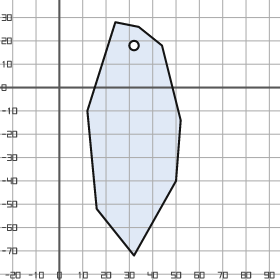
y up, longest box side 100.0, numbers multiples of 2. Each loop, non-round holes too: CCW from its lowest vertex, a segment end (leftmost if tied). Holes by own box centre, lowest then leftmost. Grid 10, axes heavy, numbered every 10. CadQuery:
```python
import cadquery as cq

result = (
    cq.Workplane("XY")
    .moveTo(32.0, -72.0)
    .lineTo(50.0, -40.0)
    .lineTo(52.0, -14.0)
    .lineTo(44.0, 18.0)
    .lineTo(34.0, 26.0)
    .lineTo(24.0, 28.0)
    .lineTo(12.0, -10.0)
    .lineTo(16.0, -52.0)
    .close()
    .moveTo(32.0, 18.0)
    .circle(2.0)
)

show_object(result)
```